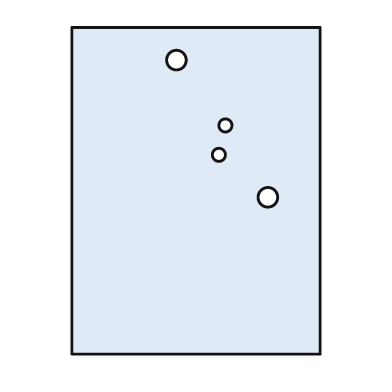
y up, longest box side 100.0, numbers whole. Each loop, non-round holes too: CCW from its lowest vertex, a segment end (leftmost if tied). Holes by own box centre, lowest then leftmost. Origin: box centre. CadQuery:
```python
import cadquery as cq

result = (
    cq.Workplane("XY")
    .moveTo(-38.0, -50.0)
    .lineTo(38.0, -50.0)
    .lineTo(38.0, 50.0)
    .lineTo(-38.0, 50.0)
    .close()
    .moveTo(22.0, -2.0)
    .circle(3.0)
    .moveTo(7.0, 11.0)
    .circle(2.0)
    .moveTo(9.0, 20.0)
    .circle(2.0)
    .moveTo(-6.0, 40.0)
    .circle(3.0)
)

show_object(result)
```